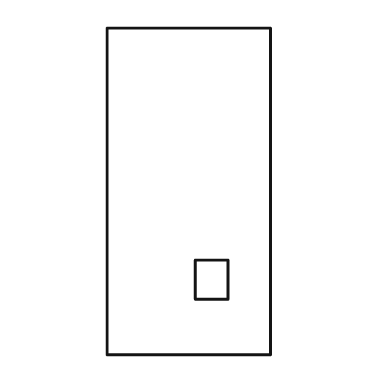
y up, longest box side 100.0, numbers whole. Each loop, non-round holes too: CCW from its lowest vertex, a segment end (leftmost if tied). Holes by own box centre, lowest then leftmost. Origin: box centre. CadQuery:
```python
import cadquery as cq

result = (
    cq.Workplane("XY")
    .moveTo(-25.0, -50.0)
    .lineTo(25.0, -50.0)
    .lineTo(25.0, 50.0)
    .lineTo(-25.0, 50.0)
    .close()
    .moveTo(2.0, -33.0)
    .lineTo(12.0, -33.0)
    .lineTo(12.0, -21.0)
    .lineTo(2.0, -21.0)
    .close()
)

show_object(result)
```